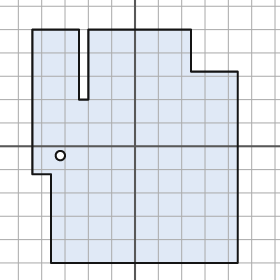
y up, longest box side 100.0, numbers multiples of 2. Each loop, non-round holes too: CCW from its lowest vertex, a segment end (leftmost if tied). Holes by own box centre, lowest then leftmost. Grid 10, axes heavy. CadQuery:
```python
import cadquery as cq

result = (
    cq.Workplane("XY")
    .moveTo(-36.0, -50.0)
    .lineTo(44.0, -50.0)
    .lineTo(44.0, 32.0)
    .lineTo(24.0, 32.0)
    .lineTo(24.0, 50.0)
    .lineTo(-20.0, 50.0)
    .lineTo(-20.0, 20.0)
    .lineTo(-24.0, 20.0)
    .lineTo(-24.0, 50.0)
    .lineTo(-44.0, 50.0)
    .lineTo(-44.0, -12.0)
    .lineTo(-36.0, -12.0)
    .close()
    .moveTo(-32.0, -4.0)
    .circle(2.0)
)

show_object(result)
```